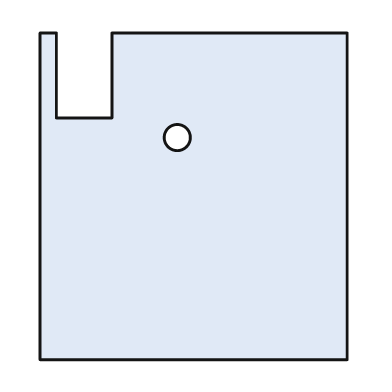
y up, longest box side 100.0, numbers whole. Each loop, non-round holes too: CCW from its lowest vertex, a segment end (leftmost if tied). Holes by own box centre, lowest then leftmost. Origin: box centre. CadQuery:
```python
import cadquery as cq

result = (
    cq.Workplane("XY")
    .moveTo(-47.0, -50.0)
    .lineTo(47.0, -50.0)
    .lineTo(47.0, 50.0)
    .lineTo(-25.0, 50.0)
    .lineTo(-25.0, 24.0)
    .lineTo(-42.0, 24.0)
    .lineTo(-42.0, 50.0)
    .lineTo(-47.0, 50.0)
    .close()
    .moveTo(-5.0, 18.0)
    .circle(4.0)
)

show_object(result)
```